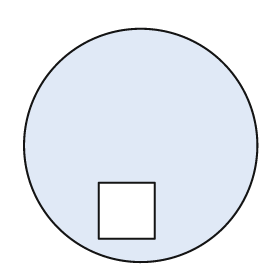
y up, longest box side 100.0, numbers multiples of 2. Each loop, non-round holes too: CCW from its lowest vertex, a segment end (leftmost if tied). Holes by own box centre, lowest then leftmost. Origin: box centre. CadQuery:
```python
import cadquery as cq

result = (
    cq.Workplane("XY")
    .moveTo(0.0, 0.0)
    .circle(50.0)
    .moveTo(-18.0, -40.0)
    .lineTo(6.0, -40.0)
    .lineTo(6.0, -16.0)
    .lineTo(-18.0, -16.0)
    .close()
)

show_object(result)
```